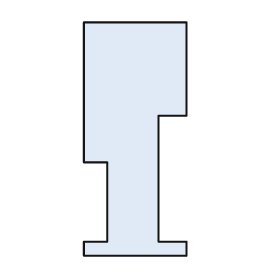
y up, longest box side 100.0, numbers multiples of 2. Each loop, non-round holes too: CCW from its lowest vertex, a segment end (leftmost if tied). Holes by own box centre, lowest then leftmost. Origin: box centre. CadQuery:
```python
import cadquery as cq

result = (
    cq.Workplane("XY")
    .moveTo(-22.0, -50.0)
    .lineTo(22.0, -50.0)
    .lineTo(22.0, -44.0)
    .lineTo(10.0, -44.0)
    .lineTo(10.0, 10.0)
    .lineTo(22.0, 10.0)
    .lineTo(22.0, 50.0)
    .lineTo(-22.0, 50.0)
    .lineTo(-22.0, -10.0)
    .lineTo(-12.0, -10.0)
    .lineTo(-12.0, -44.0)
    .lineTo(-22.0, -44.0)
    .close()
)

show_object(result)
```